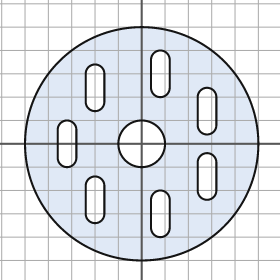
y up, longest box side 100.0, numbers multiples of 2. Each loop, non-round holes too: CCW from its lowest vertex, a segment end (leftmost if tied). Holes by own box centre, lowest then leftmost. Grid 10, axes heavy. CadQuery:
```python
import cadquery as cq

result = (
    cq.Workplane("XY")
    .moveTo(0.0, 0.0)
    .circle(50.0)
    .moveTo(4.0, -36.0)
    .threePointArc((8.0, -40.0), (12.0, -36.0))
    .lineTo(12.0, -24.0)
    .threePointArc((8.0, -20.0), (4.0, -24.0))
    .close()
    .moveTo(-24.0, -30.0)
    .threePointArc((-20.0, -34.0), (-16.0, -30.0))
    .lineTo(-16.0, -18.0)
    .threePointArc((-20.0, -14.0), (-24.0, -18.0))
    .close()
    .moveTo(24.0, -20.0)
    .threePointArc((28.0, -24.0), (32.0, -20.0))
    .lineTo(32.0, -8.0)
    .threePointArc((28.0, -4.0), (24.0, -8.0))
    .close()
    .moveTo(-36.0, -6.0)
    .threePointArc((-32.0, -10.0), (-28.0, -6.0))
    .lineTo(-28.0, 6.0)
    .threePointArc((-32.0, 10.0), (-36.0, 6.0))
    .close()
    .moveTo(0.0, 0.0)
    .circle(10.0)
    .moveTo(24.0, 8.0)
    .threePointArc((28.0, 4.0), (32.0, 8.0))
    .lineTo(32.0, 20.0)
    .threePointArc((28.0, 24.0), (24.0, 20.0))
    .close()
    .moveTo(-24.0, 18.0)
    .threePointArc((-20.0, 14.0), (-16.0, 18.0))
    .lineTo(-16.0, 30.0)
    .threePointArc((-20.0, 34.0), (-24.0, 30.0))
    .close()
    .moveTo(4.0, 24.0)
    .threePointArc((8.0, 20.0), (12.0, 24.0))
    .lineTo(12.0, 36.0)
    .threePointArc((8.0, 40.0), (4.0, 36.0))
    .close()
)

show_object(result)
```